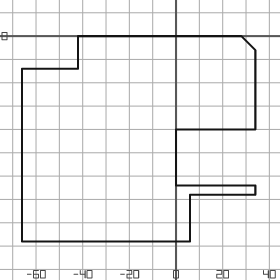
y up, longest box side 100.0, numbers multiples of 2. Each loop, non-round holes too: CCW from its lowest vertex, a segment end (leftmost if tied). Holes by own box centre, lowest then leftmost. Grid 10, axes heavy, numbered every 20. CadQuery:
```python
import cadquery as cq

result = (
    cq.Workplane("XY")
    .moveTo(-66.0, -88.0)
    .lineTo(6.0, -88.0)
    .lineTo(6.0, -68.0)
    .lineTo(34.0, -68.0)
    .lineTo(34.0, -64.0)
    .lineTo(0.0, -64.0)
    .lineTo(0.0, -40.0)
    .lineTo(34.0, -40.0)
    .lineTo(34.0, -6.0)
    .lineTo(28.0, 0.0)
    .lineTo(-42.0, 0.0)
    .lineTo(-42.0, -14.0)
    .lineTo(-66.0, -14.0)
    .close()
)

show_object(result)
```